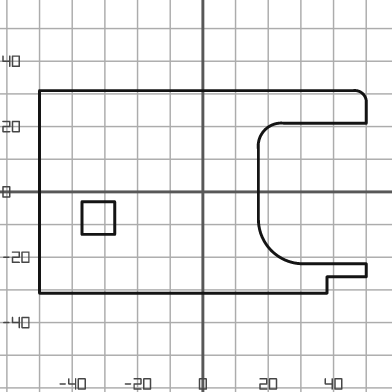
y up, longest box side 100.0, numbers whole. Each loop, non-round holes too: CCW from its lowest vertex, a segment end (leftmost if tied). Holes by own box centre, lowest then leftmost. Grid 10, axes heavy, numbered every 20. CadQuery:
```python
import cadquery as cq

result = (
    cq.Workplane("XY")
    .moveTo(-50.0, -31.0)
    .lineTo(38.0, -31.0)
    .lineTo(38.0, -26.0)
    .lineTo(50.0, -26.0)
    .lineTo(50.0, -22.0)
    .lineTo(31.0, -22.0)
    .threePointArc((21.0, -18.0), (17.0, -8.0))
    .lineTo(17.0, 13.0)
    .threePointArc((19.0, 19.0), (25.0, 21.0))
    .lineTo(50.0, 21.0)
    .lineTo(50.0, 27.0)
    .threePointArc((49.0, 30.0), (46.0, 31.0))
    .lineTo(-50.0, 31.0)
    .close()
    .moveTo(-37.0, -13.0)
    .lineTo(-27.0, -13.0)
    .lineTo(-27.0, -3.0)
    .lineTo(-37.0, -3.0)
    .close()
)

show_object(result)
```